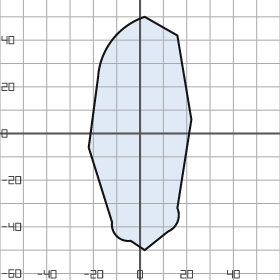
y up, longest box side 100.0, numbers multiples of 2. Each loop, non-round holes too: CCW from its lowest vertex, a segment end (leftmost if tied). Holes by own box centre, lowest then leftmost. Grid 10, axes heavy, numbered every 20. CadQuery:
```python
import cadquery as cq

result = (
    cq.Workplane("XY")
    .moveTo(2.0, -50.0)
    .lineTo(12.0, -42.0)
    .threePointArc((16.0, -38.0), (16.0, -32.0))
    .lineTo(22.0, 6.0)
    .lineTo(16.0, 42.0)
    .lineTo(2.0, 50.0)
    .threePointArc((-12.0, 40.0), (-18.0, 24.0))
    .lineTo(-22.0, -6.0)
    .lineTo(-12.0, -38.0)
    .threePointArc((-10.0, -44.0), (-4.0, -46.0))
    .close()
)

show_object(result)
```